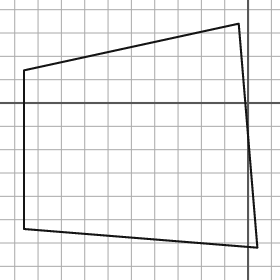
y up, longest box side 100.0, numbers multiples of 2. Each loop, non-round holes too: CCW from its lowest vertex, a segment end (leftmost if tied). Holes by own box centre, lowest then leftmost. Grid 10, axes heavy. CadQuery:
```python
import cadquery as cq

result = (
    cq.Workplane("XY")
    .moveTo(4.0, -62.0)
    .lineTo(-4.0, 34.0)
    .lineTo(-96.0, 14.0)
    .lineTo(-96.0, -54.0)
    .close()
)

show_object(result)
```